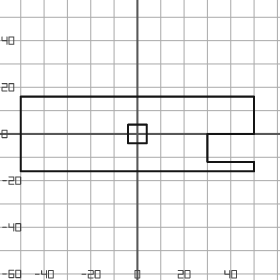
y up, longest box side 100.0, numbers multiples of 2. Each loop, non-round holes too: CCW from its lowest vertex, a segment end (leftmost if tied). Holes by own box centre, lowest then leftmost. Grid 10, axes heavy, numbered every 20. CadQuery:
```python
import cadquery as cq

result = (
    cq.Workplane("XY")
    .moveTo(-50.0, -16.0)
    .lineTo(50.0, -16.0)
    .lineTo(50.0, -12.0)
    .lineTo(30.0, -12.0)
    .lineTo(30.0, 0.0)
    .lineTo(50.0, 0.0)
    .lineTo(50.0, 16.0)
    .lineTo(-50.0, 16.0)
    .close()
    .moveTo(-4.0, -4.0)
    .lineTo(4.0, -4.0)
    .lineTo(4.0, 4.0)
    .lineTo(-4.0, 4.0)
    .close()
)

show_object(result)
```